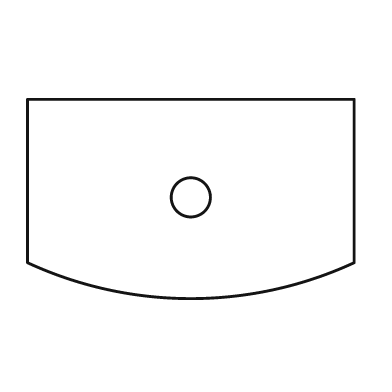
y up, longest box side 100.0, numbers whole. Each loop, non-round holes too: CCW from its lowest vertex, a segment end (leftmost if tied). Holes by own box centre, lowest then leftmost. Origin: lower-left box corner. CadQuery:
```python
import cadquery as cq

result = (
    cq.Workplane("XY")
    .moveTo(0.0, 11.0)
    .threePointArc((50.0, 0.0), (100.0, 11.0))
    .lineTo(100.0, 61.0)
    .lineTo(0.0, 61.0)
    .close()
    .moveTo(50.0, 31.0)
    .circle(6.0)
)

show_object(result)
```